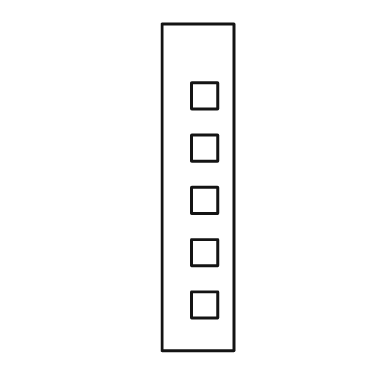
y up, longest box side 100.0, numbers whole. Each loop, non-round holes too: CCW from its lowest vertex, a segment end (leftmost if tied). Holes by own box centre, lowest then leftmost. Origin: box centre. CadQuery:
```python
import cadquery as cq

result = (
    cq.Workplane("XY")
    .moveTo(-11.0, -50.0)
    .lineTo(11.0, -50.0)
    .lineTo(11.0, 50.0)
    .lineTo(-11.0, 50.0)
    .close()
    .moveTo(-2.0, -40.0)
    .lineTo(6.0, -40.0)
    .lineTo(6.0, -32.0)
    .lineTo(-2.0, -32.0)
    .close()
    .moveTo(-2.0, -24.0)
    .lineTo(6.0, -24.0)
    .lineTo(6.0, -16.0)
    .lineTo(-2.0, -16.0)
    .close()
    .moveTo(-2.0, -8.0)
    .lineTo(6.0, -8.0)
    .lineTo(6.0, 0.0)
    .lineTo(-2.0, 0.0)
    .close()
    .moveTo(-2.0, 8.0)
    .lineTo(6.0, 8.0)
    .lineTo(6.0, 16.0)
    .lineTo(-2.0, 16.0)
    .close()
    .moveTo(-2.0, 24.0)
    .lineTo(6.0, 24.0)
    .lineTo(6.0, 32.0)
    .lineTo(-2.0, 32.0)
    .close()
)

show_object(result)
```